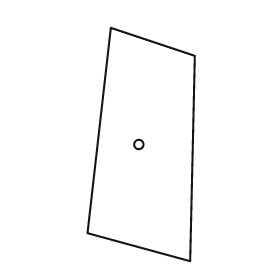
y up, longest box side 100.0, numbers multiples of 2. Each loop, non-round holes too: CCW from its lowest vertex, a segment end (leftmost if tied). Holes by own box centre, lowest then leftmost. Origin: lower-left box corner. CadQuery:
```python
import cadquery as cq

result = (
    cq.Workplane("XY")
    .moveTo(44.0, 0.0)
    .lineTo(46.0, 88.0)
    .lineTo(10.0, 100.0)
    .lineTo(0.0, 12.0)
    .close()
    .moveTo(22.0, 50.0)
    .circle(2.0)
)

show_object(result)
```